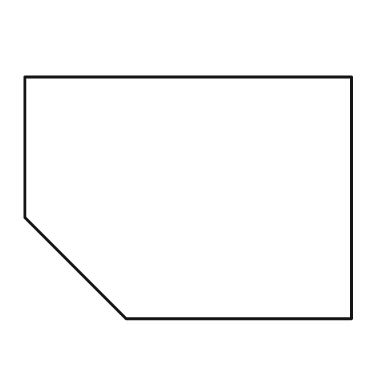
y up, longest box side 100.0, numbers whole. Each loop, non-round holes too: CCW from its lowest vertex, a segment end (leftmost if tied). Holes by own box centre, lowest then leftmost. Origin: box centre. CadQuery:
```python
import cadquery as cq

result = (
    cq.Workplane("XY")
    .moveTo(-19.0, -37.0)
    .lineTo(50.0, -37.0)
    .lineTo(50.0, 37.0)
    .lineTo(-50.0, 37.0)
    .lineTo(-50.0, -6.0)
    .close()
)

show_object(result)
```